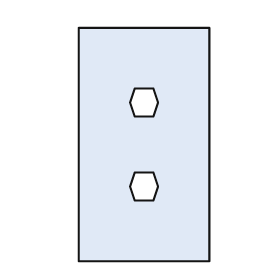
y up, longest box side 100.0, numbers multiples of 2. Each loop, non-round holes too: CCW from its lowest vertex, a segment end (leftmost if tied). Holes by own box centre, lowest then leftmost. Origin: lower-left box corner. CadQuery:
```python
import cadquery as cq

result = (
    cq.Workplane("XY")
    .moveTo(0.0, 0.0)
    .lineTo(56.0, 0.0)
    .lineTo(56.0, 100.0)
    .lineTo(0.0, 100.0)
    .close()
    .moveTo(24.0, 26.0)
    .lineTo(32.0, 26.0)
    .lineTo(34.0, 32.0)
    .lineTo(32.0, 38.0)
    .lineTo(24.0, 38.0)
    .lineTo(22.0, 32.0)
    .close()
    .moveTo(24.0, 62.0)
    .lineTo(32.0, 62.0)
    .lineTo(34.0, 68.0)
    .lineTo(32.0, 74.0)
    .lineTo(24.0, 74.0)
    .lineTo(22.0, 68.0)
    .close()
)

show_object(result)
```